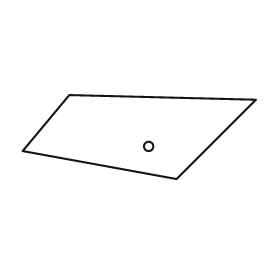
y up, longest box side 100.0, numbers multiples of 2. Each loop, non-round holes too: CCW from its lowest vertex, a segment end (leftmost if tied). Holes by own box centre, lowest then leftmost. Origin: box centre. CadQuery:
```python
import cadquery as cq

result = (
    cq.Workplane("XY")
    .moveTo(16.0, -18.0)
    .lineTo(50.0, 16.0)
    .lineTo(-30.0, 18.0)
    .lineTo(-50.0, -6.0)
    .close()
    .moveTo(4.0, -4.0)
    .circle(2.0)
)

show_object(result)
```